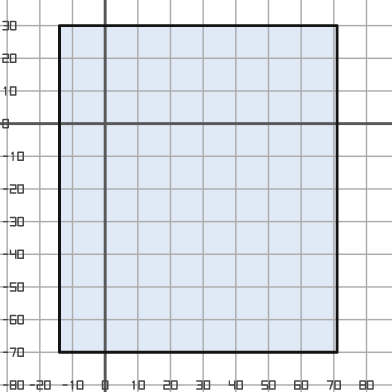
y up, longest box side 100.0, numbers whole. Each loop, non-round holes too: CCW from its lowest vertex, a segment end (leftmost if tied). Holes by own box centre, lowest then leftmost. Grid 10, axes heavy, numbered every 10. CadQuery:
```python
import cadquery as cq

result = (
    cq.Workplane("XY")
    .moveTo(-14.0, -70.0)
    .lineTo(71.0, -70.0)
    .lineTo(71.0, 30.0)
    .lineTo(-14.0, 30.0)
    .close()
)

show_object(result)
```